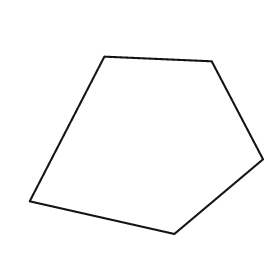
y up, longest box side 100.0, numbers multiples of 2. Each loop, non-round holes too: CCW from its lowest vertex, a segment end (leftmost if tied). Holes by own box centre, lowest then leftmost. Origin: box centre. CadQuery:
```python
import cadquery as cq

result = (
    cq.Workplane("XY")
    .moveTo(12.0, -38.0)
    .lineTo(50.0, -6.0)
    .lineTo(28.0, 36.0)
    .lineTo(-18.0, 38.0)
    .lineTo(-50.0, -24.0)
    .close()
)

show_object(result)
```